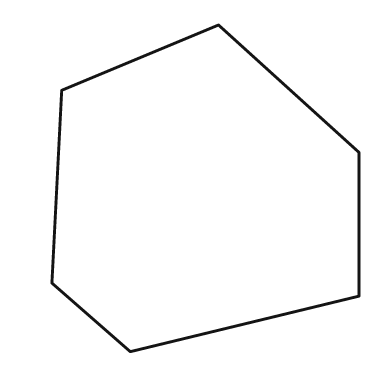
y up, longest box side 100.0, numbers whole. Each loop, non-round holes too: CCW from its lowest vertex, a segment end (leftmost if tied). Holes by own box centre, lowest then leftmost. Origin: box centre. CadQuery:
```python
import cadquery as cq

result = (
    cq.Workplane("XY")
    .moveTo(-23.0, -50.0)
    .lineTo(47.0, -33.0)
    .lineTo(47.0, 11.0)
    .lineTo(4.0, 50.0)
    .lineTo(-44.0, 30.0)
    .lineTo(-47.0, -29.0)
    .close()
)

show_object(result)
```